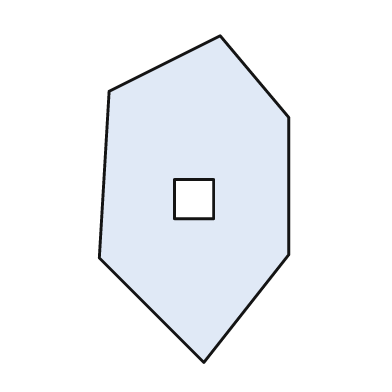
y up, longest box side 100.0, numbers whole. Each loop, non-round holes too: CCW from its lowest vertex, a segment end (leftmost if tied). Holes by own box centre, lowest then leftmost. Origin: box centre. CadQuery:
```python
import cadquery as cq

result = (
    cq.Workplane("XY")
    .moveTo(3.0, -50.0)
    .lineTo(29.0, -17.0)
    .lineTo(29.0, 25.0)
    .lineTo(8.0, 50.0)
    .lineTo(-26.0, 33.0)
    .lineTo(-29.0, -18.0)
    .close()
    .moveTo(-6.0, -6.0)
    .lineTo(6.0, -6.0)
    .lineTo(6.0, 6.0)
    .lineTo(-6.0, 6.0)
    .close()
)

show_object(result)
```